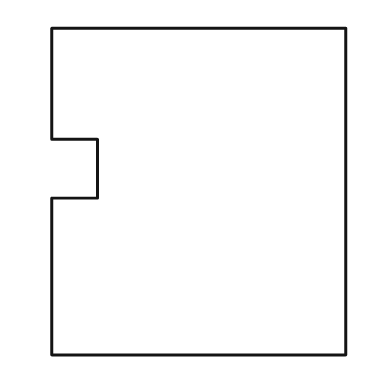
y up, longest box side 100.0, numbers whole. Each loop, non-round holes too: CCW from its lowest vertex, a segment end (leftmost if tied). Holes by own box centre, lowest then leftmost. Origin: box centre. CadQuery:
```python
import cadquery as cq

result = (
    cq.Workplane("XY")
    .moveTo(-45.0, -50.0)
    .lineTo(45.0, -50.0)
    .lineTo(45.0, 50.0)
    .lineTo(-45.0, 50.0)
    .lineTo(-45.0, 16.0)
    .lineTo(-31.0, 16.0)
    .lineTo(-31.0, -2.0)
    .lineTo(-45.0, -2.0)
    .close()
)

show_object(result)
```